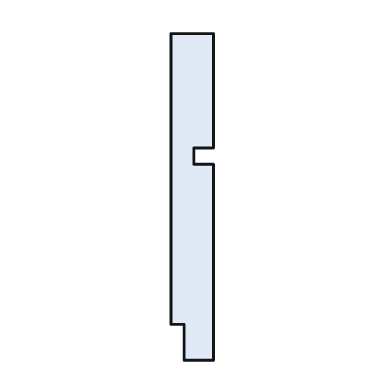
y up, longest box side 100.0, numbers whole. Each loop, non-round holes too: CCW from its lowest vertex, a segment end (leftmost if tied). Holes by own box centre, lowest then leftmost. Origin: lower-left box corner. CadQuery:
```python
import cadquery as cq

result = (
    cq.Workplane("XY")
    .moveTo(4.0, 0.0)
    .lineTo(13.0, 0.0)
    .lineTo(13.0, 60.0)
    .lineTo(7.0, 60.0)
    .lineTo(7.0, 65.0)
    .lineTo(13.0, 65.0)
    .lineTo(13.0, 100.0)
    .lineTo(0.0, 100.0)
    .lineTo(0.0, 11.0)
    .lineTo(4.0, 11.0)
    .close()
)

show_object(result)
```